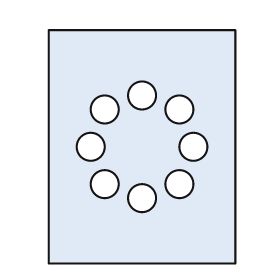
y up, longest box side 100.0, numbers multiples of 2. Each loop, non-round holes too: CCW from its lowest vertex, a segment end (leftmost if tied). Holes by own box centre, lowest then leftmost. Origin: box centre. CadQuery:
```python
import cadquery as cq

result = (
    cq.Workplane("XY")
    .moveTo(-40.0, -50.0)
    .lineTo(40.0, -50.0)
    .lineTo(40.0, 50.0)
    .lineTo(-40.0, 50.0)
    .close()
    .moveTo(0.0, -22.0)
    .circle(6.0)
    .moveTo(-16.0, -16.0)
    .circle(6.0)
    .moveTo(16.0, -16.0)
    .circle(6.0)
    .moveTo(-22.0, 0.0)
    .circle(6.0)
    .moveTo(22.0, 0.0)
    .circle(6.0)
    .moveTo(-16.0, 16.0)
    .circle(6.0)
    .moveTo(16.0, 16.0)
    .circle(6.0)
    .moveTo(0.0, 22.0)
    .circle(6.0)
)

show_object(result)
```